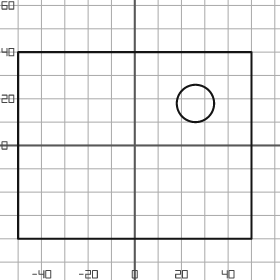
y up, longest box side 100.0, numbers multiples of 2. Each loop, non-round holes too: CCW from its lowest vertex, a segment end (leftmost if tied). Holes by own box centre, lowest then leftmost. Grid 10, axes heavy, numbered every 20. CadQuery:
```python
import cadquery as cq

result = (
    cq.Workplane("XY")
    .moveTo(-50.0, -40.0)
    .lineTo(50.0, -40.0)
    .lineTo(50.0, 40.0)
    .lineTo(-50.0, 40.0)
    .close()
    .moveTo(26.0, 18.0)
    .circle(8.0)
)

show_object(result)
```